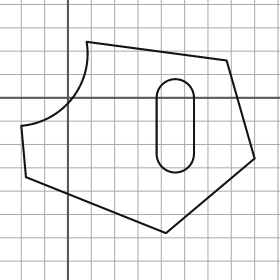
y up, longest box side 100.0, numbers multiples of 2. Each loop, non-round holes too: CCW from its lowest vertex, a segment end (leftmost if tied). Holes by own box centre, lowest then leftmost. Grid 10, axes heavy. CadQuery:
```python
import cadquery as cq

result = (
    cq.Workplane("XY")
    .moveTo(42.0, -58.0)
    .lineTo(80.0, -26.0)
    .lineTo(68.0, 16.0)
    .lineTo(8.0, 24.0)
    .threePointArc((2.0, 0.0), (-20.0, -12.0))
    .lineTo(-18.0, -34.0)
    .close()
    .moveTo(38.0, -24.0)
    .threePointArc((46.0, -32.0), (54.0, -24.0))
    .lineTo(54.0, 0.0)
    .threePointArc((46.0, 8.0), (38.0, 0.0))
    .close()
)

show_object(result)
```